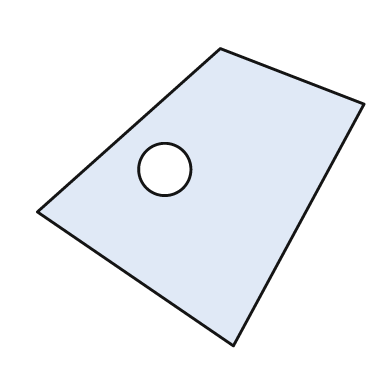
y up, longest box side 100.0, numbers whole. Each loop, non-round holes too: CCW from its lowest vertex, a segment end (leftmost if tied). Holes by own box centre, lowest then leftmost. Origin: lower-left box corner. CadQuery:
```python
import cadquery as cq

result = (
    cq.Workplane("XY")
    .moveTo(60.0, 0.0)
    .lineTo(100.0, 74.0)
    .lineTo(56.0, 91.0)
    .lineTo(0.0, 41.0)
    .close()
    .moveTo(39.0, 54.0)
    .circle(8.0)
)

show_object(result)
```